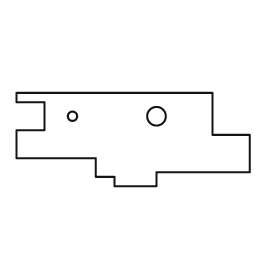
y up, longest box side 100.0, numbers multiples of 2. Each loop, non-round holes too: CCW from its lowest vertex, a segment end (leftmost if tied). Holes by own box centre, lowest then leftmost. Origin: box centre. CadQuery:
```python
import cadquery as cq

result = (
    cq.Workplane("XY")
    .moveTo(-8.0, -20.0)
    .lineTo(10.0, -20.0)
    .lineTo(10.0, -14.0)
    .lineTo(50.0, -14.0)
    .lineTo(50.0, 2.0)
    .lineTo(34.0, 2.0)
    .lineTo(34.0, 20.0)
    .lineTo(-50.0, 20.0)
    .lineTo(-50.0, 16.0)
    .lineTo(-38.0, 16.0)
    .lineTo(-38.0, 4.0)
    .lineTo(-50.0, 4.0)
    .lineTo(-50.0, -8.0)
    .lineTo(-16.0, -8.0)
    .lineTo(-16.0, -16.0)
    .lineTo(-8.0, -16.0)
    .close()
    .moveTo(-26.0, 10.0)
    .circle(2.0)
    .moveTo(10.0, 10.0)
    .circle(4.0)
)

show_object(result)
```